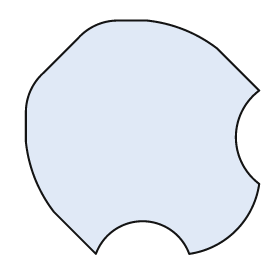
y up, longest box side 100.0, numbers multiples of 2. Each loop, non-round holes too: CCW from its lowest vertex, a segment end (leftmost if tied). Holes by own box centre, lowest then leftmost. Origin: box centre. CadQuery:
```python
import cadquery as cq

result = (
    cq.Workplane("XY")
    .moveTo(-20.0, -50.0)
    .threePointArc((0.0, -36.0), (20.0, -50.0))
    .threePointArc((40.0, -40.0), (50.0, -20.0))
    .threePointArc((40.0, 0.0), (50.0, 20.0))
    .lineTo(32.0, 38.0)
    .threePointArc((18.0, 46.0), (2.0, 50.0))
    .lineTo(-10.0, 50.0)
    .threePointArc((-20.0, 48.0), (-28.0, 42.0))
    .lineTo(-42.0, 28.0)
    .threePointArc((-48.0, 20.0), (-50.0, 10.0))
    .lineTo(-50.0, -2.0)
    .threePointArc((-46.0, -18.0), (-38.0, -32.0))
    .close()
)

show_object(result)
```